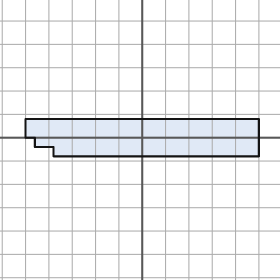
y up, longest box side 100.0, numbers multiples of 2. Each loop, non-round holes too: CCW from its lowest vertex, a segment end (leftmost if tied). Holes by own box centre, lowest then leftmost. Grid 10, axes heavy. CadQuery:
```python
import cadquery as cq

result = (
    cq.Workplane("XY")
    .moveTo(-38.0, -8.0)
    .lineTo(50.0, -8.0)
    .lineTo(50.0, 8.0)
    .lineTo(-50.0, 8.0)
    .lineTo(-50.0, 0.0)
    .lineTo(-46.0, 0.0)
    .lineTo(-46.0, -4.0)
    .lineTo(-38.0, -4.0)
    .close()
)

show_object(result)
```